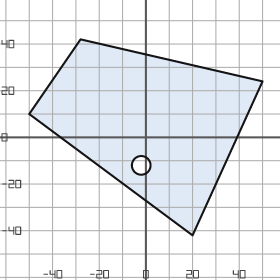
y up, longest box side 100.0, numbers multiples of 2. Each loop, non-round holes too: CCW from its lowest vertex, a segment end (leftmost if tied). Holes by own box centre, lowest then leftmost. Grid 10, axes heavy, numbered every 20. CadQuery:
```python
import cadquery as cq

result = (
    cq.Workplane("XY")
    .moveTo(20.0, -42.0)
    .lineTo(50.0, 24.0)
    .lineTo(-28.0, 42.0)
    .lineTo(-50.0, 10.0)
    .close()
    .moveTo(-2.0, -12.0)
    .circle(4.0)
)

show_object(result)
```